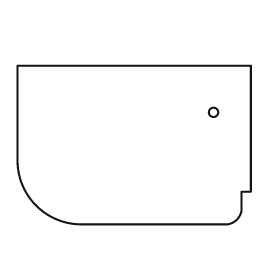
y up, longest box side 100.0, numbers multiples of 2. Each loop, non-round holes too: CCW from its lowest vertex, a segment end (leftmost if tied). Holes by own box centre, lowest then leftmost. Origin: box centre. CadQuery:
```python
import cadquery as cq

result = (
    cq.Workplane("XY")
    .moveTo(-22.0, -34.0)
    .lineTo(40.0, -34.0)
    .threePointArc((44.0, -32.0), (46.0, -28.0))
    .lineTo(46.0, -20.0)
    .lineTo(50.0, -20.0)
    .lineTo(50.0, 34.0)
    .lineTo(-50.0, 34.0)
    .lineTo(-50.0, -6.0)
    .threePointArc((-42.0, -26.0), (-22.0, -34.0))
    .close()
    .moveTo(34.0, 14.0)
    .circle(2.0)
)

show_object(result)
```